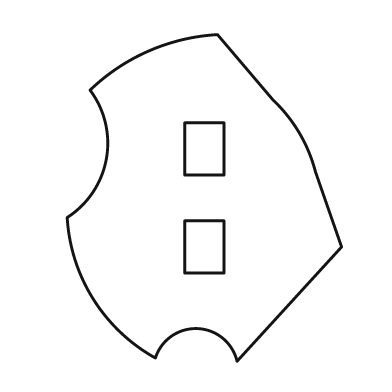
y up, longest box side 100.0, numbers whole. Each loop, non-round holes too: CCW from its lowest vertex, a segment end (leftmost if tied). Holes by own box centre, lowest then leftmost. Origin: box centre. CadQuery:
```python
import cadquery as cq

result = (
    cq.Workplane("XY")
    .moveTo(10.0, -50.0)
    .lineTo(42.0, -15.0)
    .lineTo(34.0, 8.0)
    .threePointArc((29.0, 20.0), (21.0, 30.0))
    .lineTo(4.0, 50.0)
    .threePointArc((-17.0, 45.0), (-35.0, 33.0))
    .threePointArc((-30.0, 12.0), (-42.0, -6.0))
    .threePointArc((-34.0, -31.0), (-15.0, -49.0))
    .threePointArc((-2.0, -40.0), (10.0, -50.0))
    .close()
    .moveTo(-6.0, -23.0)
    .lineTo(6.0, -23.0)
    .lineTo(6.0, -7.0)
    .lineTo(-6.0, -7.0)
    .close()
    .moveTo(-6.0, 7.0)
    .lineTo(6.0, 7.0)
    .lineTo(6.0, 23.0)
    .lineTo(-6.0, 23.0)
    .close()
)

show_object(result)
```